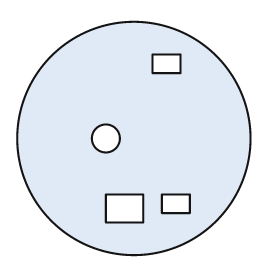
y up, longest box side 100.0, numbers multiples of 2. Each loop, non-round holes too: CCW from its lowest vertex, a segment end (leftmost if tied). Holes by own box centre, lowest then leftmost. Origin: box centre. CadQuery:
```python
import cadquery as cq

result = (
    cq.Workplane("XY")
    .moveTo(0.0, 0.0)
    .circle(50.0)
    .moveTo(-12.0, -36.0)
    .lineTo(4.0, -36.0)
    .lineTo(4.0, -24.0)
    .lineTo(-12.0, -24.0)
    .close()
    .moveTo(12.0, -32.0)
    .lineTo(24.0, -32.0)
    .lineTo(24.0, -24.0)
    .lineTo(12.0, -24.0)
    .close()
    .moveTo(-12.0, 0.0)
    .circle(6.0)
    .moveTo(8.0, 28.0)
    .lineTo(20.0, 28.0)
    .lineTo(20.0, 36.0)
    .lineTo(8.0, 36.0)
    .close()
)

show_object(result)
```